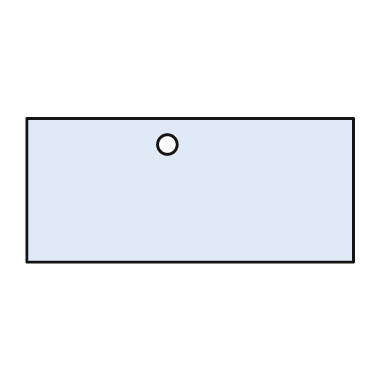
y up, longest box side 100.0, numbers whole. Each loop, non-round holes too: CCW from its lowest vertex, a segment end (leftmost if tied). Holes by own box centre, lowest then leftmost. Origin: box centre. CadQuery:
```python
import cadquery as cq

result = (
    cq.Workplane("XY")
    .moveTo(-50.0, -22.0)
    .lineTo(50.0, -22.0)
    .lineTo(50.0, 22.0)
    .lineTo(-50.0, 22.0)
    .close()
    .moveTo(-7.0, 14.0)
    .circle(3.0)
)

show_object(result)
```